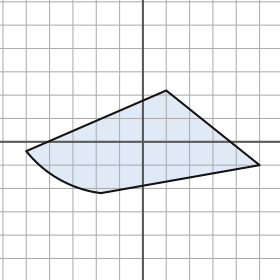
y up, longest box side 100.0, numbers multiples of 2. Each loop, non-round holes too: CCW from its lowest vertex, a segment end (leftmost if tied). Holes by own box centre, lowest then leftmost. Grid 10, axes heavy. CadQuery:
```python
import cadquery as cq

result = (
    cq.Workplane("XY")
    .moveTo(-18.0, -22.0)
    .lineTo(50.0, -10.0)
    .lineTo(10.0, 22.0)
    .lineTo(-50.0, -4.0)
    .threePointArc((-36.0, -16.0), (-18.0, -22.0))
    .close()
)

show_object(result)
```